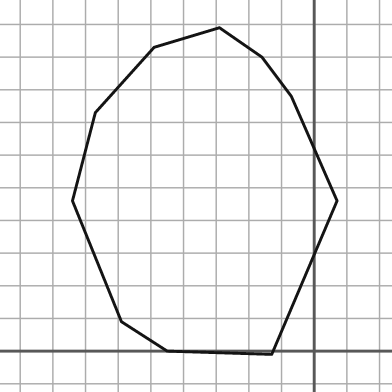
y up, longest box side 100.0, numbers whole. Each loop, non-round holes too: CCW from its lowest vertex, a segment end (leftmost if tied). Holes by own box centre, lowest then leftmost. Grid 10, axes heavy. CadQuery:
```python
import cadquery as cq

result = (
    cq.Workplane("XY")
    .moveTo(-13.0, -1.0)
    .lineTo(7.0, 46.0)
    .lineTo(-7.0, 78.0)
    .lineTo(-16.0, 90.0)
    .lineTo(-29.0, 99.0)
    .lineTo(-49.0, 93.0)
    .lineTo(-67.0, 73.0)
    .lineTo(-74.0, 46.0)
    .lineTo(-59.0, 9.0)
    .lineTo(-45.0, 0.0)
    .close()
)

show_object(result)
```